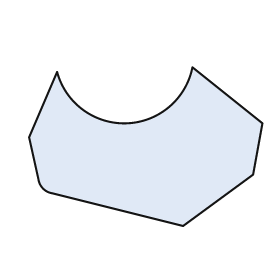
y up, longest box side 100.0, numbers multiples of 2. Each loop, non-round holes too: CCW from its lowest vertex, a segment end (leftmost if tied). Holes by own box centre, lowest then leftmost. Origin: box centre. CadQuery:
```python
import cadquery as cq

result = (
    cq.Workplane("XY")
    .moveTo(16.0, -34.0)
    .lineTo(46.0, -12.0)
    .lineTo(50.0, 10.0)
    .lineTo(20.0, 34.0)
    .threePointArc((-8.0, 10.0), (-38.0, 32.0))
    .lineTo(-50.0, 4.0)
    .lineTo(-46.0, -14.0)
    .threePointArc((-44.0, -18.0), (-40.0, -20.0))
    .close()
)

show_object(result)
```